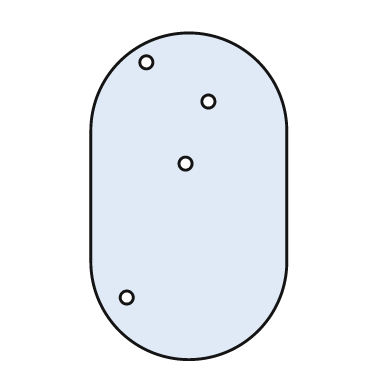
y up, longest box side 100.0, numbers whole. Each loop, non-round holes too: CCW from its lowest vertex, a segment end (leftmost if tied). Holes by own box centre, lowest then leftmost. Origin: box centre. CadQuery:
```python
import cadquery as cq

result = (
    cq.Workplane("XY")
    .moveTo(-30.0, -20.0)
    .threePointArc((0.0, -50.0), (30.0, -20.0))
    .lineTo(30.0, 20.0)
    .threePointArc((0.0, 50.0), (-30.0, 20.0))
    .close()
    .moveTo(-19.0, -31.0)
    .circle(2.0)
    .moveTo(-1.0, 10.0)
    .circle(2.0)
    .moveTo(6.0, 29.0)
    .circle(2.0)
    .moveTo(-13.0, 41.0)
    .circle(2.0)
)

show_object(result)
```